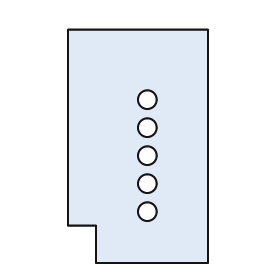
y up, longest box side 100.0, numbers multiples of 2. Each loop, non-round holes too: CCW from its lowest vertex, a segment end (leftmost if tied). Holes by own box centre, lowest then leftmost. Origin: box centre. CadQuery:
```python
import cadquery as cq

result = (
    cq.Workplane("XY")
    .moveTo(-18.0, -50.0)
    .lineTo(30.0, -50.0)
    .lineTo(30.0, 50.0)
    .lineTo(-30.0, 50.0)
    .lineTo(-30.0, -34.0)
    .lineTo(-18.0, -34.0)
    .close()
    .moveTo(4.0, -28.0)
    .circle(4.0)
    .moveTo(4.0, -16.0)
    .circle(4.0)
    .moveTo(4.0, -4.0)
    .circle(4.0)
    .moveTo(4.0, 8.0)
    .circle(4.0)
    .moveTo(4.0, 20.0)
    .circle(4.0)
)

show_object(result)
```